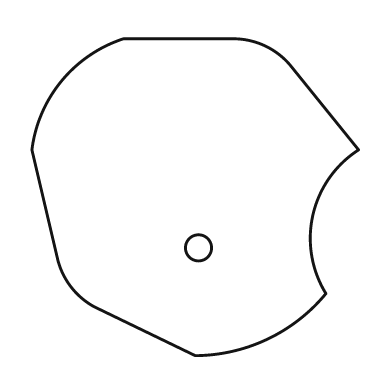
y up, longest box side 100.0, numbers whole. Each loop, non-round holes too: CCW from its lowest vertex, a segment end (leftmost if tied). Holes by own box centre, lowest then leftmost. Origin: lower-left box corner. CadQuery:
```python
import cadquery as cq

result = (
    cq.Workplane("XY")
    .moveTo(50.0, 0.0)
    .threePointArc((72.0, 5.0), (90.0, 19.0))
    .threePointArc((86.0, 43.0), (100.0, 63.0))
    .lineTo(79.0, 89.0)
    .threePointArc((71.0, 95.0), (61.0, 97.0))
    .lineTo(28.0, 97.0)
    .threePointArc((9.0, 84.0), (0.0, 63.0))
    .lineTo(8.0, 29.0)
    .threePointArc((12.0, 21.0), (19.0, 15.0))
    .close()
    .moveTo(51.0, 33.0)
    .circle(4.0)
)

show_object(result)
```